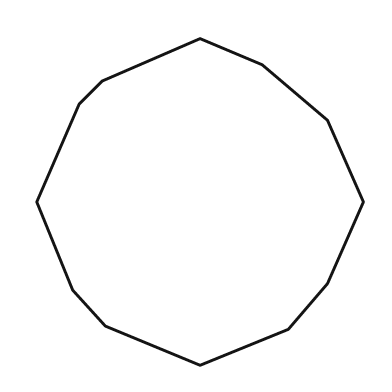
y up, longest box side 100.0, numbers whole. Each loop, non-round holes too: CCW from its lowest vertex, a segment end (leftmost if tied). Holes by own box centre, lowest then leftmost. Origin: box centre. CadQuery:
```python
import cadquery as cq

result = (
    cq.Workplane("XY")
    .moveTo(0.0, -50.0)
    .lineTo(27.0, -39.0)
    .lineTo(39.0, -25.0)
    .lineTo(50.0, 0.0)
    .lineTo(39.0, 25.0)
    .lineTo(19.0, 42.0)
    .lineTo(0.0, 50.0)
    .lineTo(-30.0, 37.0)
    .lineTo(-37.0, 30.0)
    .lineTo(-50.0, 0.0)
    .lineTo(-39.0, -27.0)
    .lineTo(-29.0, -38.0)
    .close()
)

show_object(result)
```